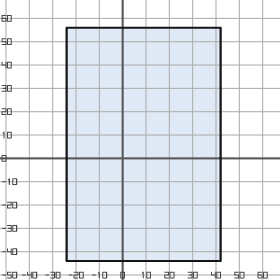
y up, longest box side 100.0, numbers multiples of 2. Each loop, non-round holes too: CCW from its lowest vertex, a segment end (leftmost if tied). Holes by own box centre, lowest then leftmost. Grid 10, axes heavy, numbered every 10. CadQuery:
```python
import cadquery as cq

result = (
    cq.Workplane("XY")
    .moveTo(-24.0, -44.0)
    .lineTo(42.0, -44.0)
    .lineTo(42.0, 56.0)
    .lineTo(-24.0, 56.0)
    .close()
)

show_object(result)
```